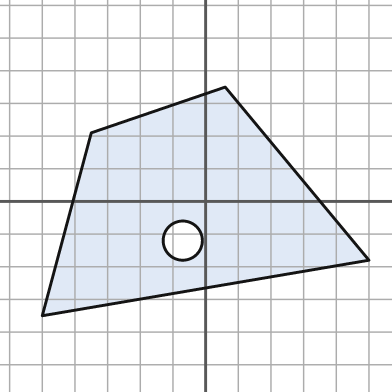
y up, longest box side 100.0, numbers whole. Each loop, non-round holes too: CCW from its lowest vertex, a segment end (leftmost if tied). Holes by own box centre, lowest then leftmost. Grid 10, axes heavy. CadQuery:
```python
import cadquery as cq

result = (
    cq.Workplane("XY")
    .moveTo(-50.0, -35.0)
    .lineTo(50.0, -18.0)
    .lineTo(6.0, 35.0)
    .lineTo(-35.0, 21.0)
    .close()
    .moveTo(-7.0, -12.0)
    .circle(6.0)
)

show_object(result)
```